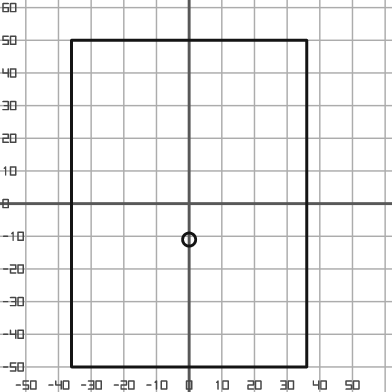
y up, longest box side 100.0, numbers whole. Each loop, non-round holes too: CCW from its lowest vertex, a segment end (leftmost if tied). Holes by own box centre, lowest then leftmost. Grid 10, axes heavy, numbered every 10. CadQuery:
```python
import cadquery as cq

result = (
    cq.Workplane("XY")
    .moveTo(-36.0, -50.0)
    .lineTo(36.0, -50.0)
    .lineTo(36.0, 50.0)
    .lineTo(-36.0, 50.0)
    .close()
    .moveTo(0.0, -11.0)
    .circle(2.0)
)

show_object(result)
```